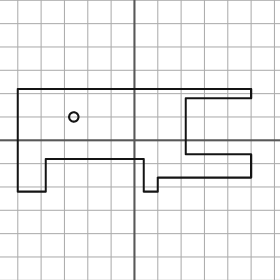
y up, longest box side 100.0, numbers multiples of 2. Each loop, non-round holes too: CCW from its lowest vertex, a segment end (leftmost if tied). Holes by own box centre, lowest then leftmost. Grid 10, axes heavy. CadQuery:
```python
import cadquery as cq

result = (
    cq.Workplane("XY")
    .moveTo(-50.0, -22.0)
    .lineTo(-38.0, -22.0)
    .lineTo(-38.0, -8.0)
    .lineTo(4.0, -8.0)
    .lineTo(4.0, -22.0)
    .lineTo(10.0, -22.0)
    .lineTo(10.0, -16.0)
    .lineTo(50.0, -16.0)
    .lineTo(50.0, -6.0)
    .lineTo(22.0, -6.0)
    .lineTo(22.0, 18.0)
    .lineTo(50.0, 18.0)
    .lineTo(50.0, 22.0)
    .lineTo(-50.0, 22.0)
    .close()
    .moveTo(-26.0, 10.0)
    .circle(2.0)
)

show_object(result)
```